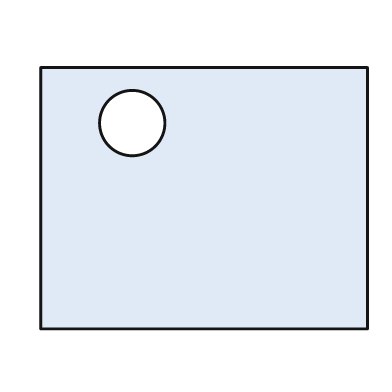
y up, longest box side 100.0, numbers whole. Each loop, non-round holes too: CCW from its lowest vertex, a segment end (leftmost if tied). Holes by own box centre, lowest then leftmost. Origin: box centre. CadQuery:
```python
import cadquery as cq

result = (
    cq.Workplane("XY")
    .moveTo(-50.0, -40.0)
    .lineTo(50.0, -40.0)
    .lineTo(50.0, 40.0)
    .lineTo(-50.0, 40.0)
    .close()
    .moveTo(-22.0, 23.0)
    .circle(10.0)
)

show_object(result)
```